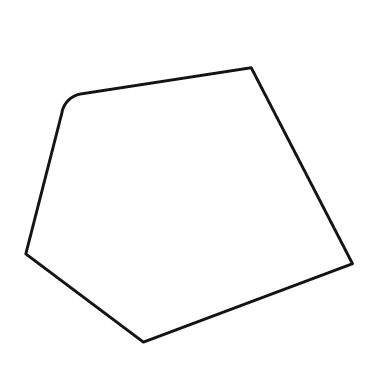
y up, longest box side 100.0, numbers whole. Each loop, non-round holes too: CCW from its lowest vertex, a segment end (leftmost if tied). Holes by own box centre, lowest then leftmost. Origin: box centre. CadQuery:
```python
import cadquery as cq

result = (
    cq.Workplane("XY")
    .moveTo(-14.0, -42.0)
    .lineTo(50.0, -18.0)
    .lineTo(19.0, 42.0)
    .lineTo(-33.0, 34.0)
    .threePointArc((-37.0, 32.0), (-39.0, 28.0))
    .lineTo(-50.0, -15.0)
    .close()
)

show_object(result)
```